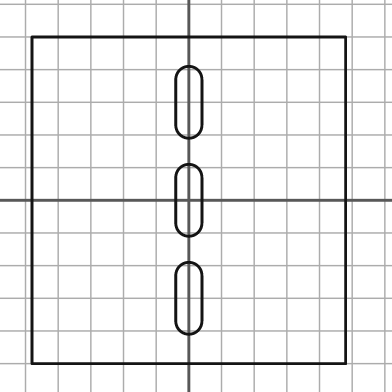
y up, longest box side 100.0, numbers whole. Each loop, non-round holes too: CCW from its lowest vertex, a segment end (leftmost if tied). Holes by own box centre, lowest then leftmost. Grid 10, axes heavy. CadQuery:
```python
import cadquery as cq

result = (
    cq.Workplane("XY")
    .moveTo(-48.0, -50.0)
    .lineTo(48.0, -50.0)
    .lineTo(48.0, 50.0)
    .lineTo(-48.0, 50.0)
    .close()
    .moveTo(-4.0, -37.0)
    .threePointArc((0.0, -41.0), (4.0, -37.0))
    .lineTo(4.0, -23.0)
    .threePointArc((0.0, -19.0), (-4.0, -23.0))
    .close()
    .moveTo(-4.0, -7.0)
    .threePointArc((0.0, -11.0), (4.0, -7.0))
    .lineTo(4.0, 7.0)
    .threePointArc((0.0, 11.0), (-4.0, 7.0))
    .close()
    .moveTo(-4.0, 23.0)
    .threePointArc((0.0, 19.0), (4.0, 23.0))
    .lineTo(4.0, 37.0)
    .threePointArc((0.0, 41.0), (-4.0, 37.0))
    .close()
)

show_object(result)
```